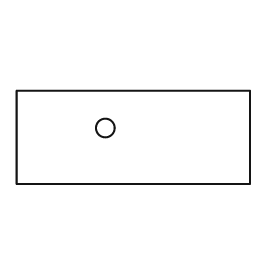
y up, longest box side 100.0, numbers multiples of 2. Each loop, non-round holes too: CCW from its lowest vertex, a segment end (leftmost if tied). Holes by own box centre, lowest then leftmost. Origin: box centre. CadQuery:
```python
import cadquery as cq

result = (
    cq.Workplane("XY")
    .moveTo(-50.0, -20.0)
    .lineTo(50.0, -20.0)
    .lineTo(50.0, 20.0)
    .lineTo(-50.0, 20.0)
    .close()
    .moveTo(-12.0, 4.0)
    .circle(4.0)
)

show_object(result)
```